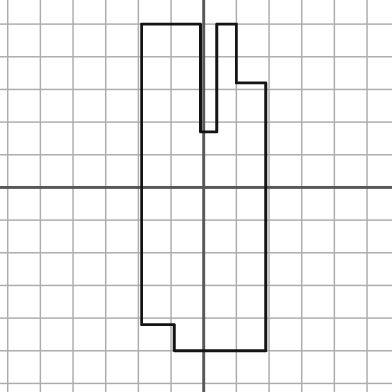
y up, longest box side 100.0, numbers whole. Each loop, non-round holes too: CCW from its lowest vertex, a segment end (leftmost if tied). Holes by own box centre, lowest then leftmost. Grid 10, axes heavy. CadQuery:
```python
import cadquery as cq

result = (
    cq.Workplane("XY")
    .moveTo(-9.0, -50.0)
    .lineTo(19.0, -50.0)
    .lineTo(19.0, 32.0)
    .lineTo(10.0, 32.0)
    .lineTo(10.0, 50.0)
    .lineTo(4.0, 50.0)
    .lineTo(4.0, 17.0)
    .lineTo(-1.0, 17.0)
    .lineTo(-1.0, 50.0)
    .lineTo(-19.0, 50.0)
    .lineTo(-19.0, -42.0)
    .lineTo(-9.0, -42.0)
    .close()
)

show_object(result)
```